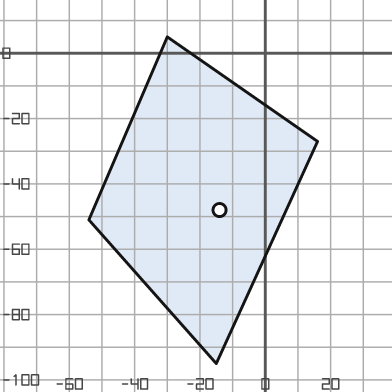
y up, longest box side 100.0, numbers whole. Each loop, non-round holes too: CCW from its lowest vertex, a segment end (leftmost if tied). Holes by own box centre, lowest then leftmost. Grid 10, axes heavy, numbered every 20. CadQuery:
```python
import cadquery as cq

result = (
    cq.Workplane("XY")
    .moveTo(-15.0, -95.0)
    .lineTo(16.0, -27.0)
    .lineTo(-30.0, 5.0)
    .lineTo(-54.0, -51.0)
    .close()
    .moveTo(-14.0, -48.0)
    .circle(2.0)
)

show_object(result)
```